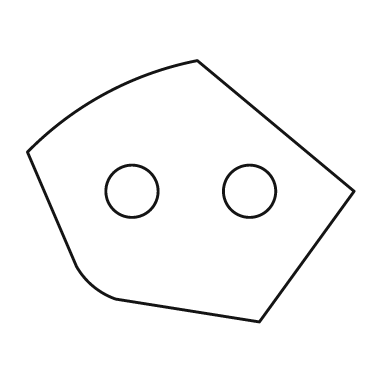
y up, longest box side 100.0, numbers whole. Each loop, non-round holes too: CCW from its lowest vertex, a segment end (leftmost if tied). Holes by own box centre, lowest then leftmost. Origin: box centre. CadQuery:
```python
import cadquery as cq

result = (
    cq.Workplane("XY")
    .moveTo(21.0, -40.0)
    .lineTo(50.0, 0.0)
    .lineTo(2.0, 40.0)
    .threePointArc((-26.0, 30.0), (-50.0, 12.0))
    .lineTo(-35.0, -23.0)
    .threePointArc((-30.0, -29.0), (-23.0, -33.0))
    .close()
    .moveTo(-18.0, 0.0)
    .circle(8.0)
    .moveTo(18.0, 0.0)
    .circle(8.0)
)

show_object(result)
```